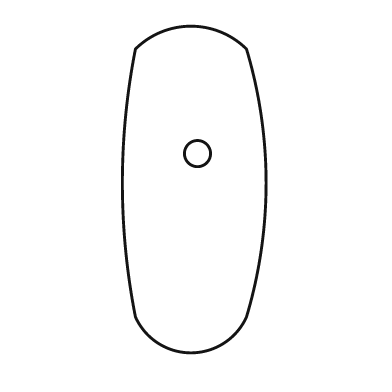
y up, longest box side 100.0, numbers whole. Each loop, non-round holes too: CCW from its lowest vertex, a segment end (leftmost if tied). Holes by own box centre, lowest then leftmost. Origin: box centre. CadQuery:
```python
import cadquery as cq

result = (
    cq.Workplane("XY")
    .moveTo(-18.0, -39.0)
    .threePointArc((-1.0, -50.0), (16.0, -39.0))
    .threePointArc((22.0, 2.0), (16.0, 43.0))
    .threePointArc((-1.0, 50.0), (-18.0, 43.0))
    .threePointArc((-22.0, 2.0), (-18.0, -39.0))
    .close()
    .moveTo(1.0, 11.0)
    .circle(4.0)
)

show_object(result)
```